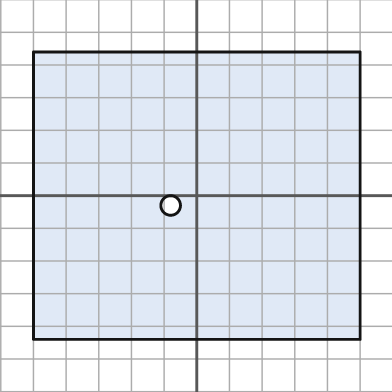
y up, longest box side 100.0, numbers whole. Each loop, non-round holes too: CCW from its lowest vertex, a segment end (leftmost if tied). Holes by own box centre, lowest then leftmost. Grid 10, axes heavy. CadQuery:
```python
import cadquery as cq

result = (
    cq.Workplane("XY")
    .moveTo(-50.0, -44.0)
    .lineTo(50.0, -44.0)
    .lineTo(50.0, 44.0)
    .lineTo(-50.0, 44.0)
    .close()
    .moveTo(-8.0, -3.0)
    .circle(3.0)
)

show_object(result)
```